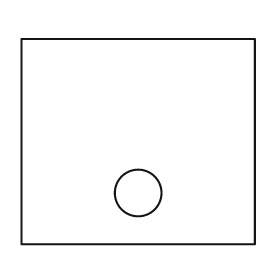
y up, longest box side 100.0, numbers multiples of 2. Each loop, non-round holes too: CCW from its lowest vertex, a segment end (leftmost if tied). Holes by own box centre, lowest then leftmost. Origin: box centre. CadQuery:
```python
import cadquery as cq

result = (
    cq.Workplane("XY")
    .moveTo(-50.0, -44.0)
    .lineTo(50.0, -44.0)
    .lineTo(50.0, 44.0)
    .lineTo(-50.0, 44.0)
    .close()
    .moveTo(0.0, -22.0)
    .circle(10.0)
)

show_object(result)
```